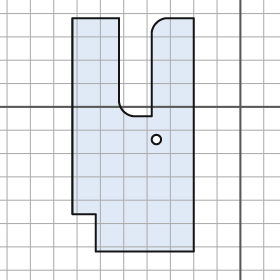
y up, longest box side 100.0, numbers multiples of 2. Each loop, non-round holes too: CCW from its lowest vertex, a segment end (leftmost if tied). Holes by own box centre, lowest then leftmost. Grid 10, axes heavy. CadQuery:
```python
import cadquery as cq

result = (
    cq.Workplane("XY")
    .moveTo(-62.0, -62.0)
    .lineTo(-20.0, -62.0)
    .lineTo(-20.0, 38.0)
    .lineTo(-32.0, 38.0)
    .threePointArc((-36.0, 36.0), (-38.0, 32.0))
    .lineTo(-38.0, -4.0)
    .lineTo(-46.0, -4.0)
    .threePointArc((-50.0, -2.0), (-52.0, 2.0))
    .lineTo(-52.0, 38.0)
    .lineTo(-72.0, 38.0)
    .lineTo(-72.0, -46.0)
    .lineTo(-62.0, -46.0)
    .close()
    .moveTo(-36.0, -14.0)
    .circle(2.0)
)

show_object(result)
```